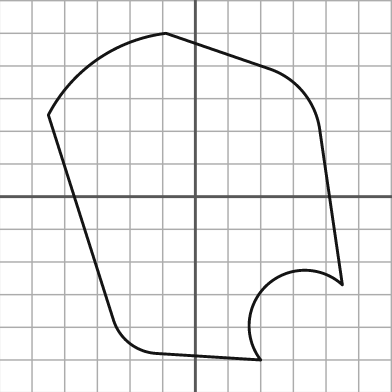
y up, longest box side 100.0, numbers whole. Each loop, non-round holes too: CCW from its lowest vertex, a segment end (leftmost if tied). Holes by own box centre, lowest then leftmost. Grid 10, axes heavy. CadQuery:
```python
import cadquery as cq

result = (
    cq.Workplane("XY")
    .moveTo(20.0, -50.0)
    .threePointArc((22.0, -27.0), (45.0, -27.0))
    .lineTo(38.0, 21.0)
    .threePointArc((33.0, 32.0), (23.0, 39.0))
    .lineTo(-9.0, 50.0)
    .threePointArc((-30.0, 42.0), (-45.0, 25.0))
    .lineTo(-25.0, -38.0)
    .threePointArc((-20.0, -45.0), (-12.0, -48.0))
    .close()
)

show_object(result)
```